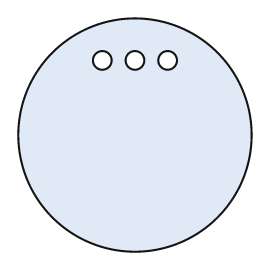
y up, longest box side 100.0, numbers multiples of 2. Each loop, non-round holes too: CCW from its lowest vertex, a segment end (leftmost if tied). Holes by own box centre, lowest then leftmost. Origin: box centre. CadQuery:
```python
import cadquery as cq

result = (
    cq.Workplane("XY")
    .moveTo(0.0, 0.0)
    .circle(50.0)
    .moveTo(-14.0, 32.0)
    .circle(4.0)
    .moveTo(0.0, 32.0)
    .circle(4.0)
    .moveTo(14.0, 32.0)
    .circle(4.0)
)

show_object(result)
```